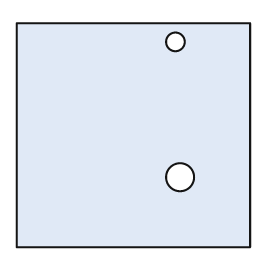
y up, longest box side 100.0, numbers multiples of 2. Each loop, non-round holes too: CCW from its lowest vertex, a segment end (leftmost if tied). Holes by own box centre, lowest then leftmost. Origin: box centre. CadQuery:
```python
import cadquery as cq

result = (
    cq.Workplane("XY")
    .moveTo(-50.0, -48.0)
    .lineTo(50.0, -48.0)
    .lineTo(50.0, 48.0)
    .lineTo(-50.0, 48.0)
    .close()
    .moveTo(20.0, -18.0)
    .circle(6.0)
    .moveTo(18.0, 40.0)
    .circle(4.0)
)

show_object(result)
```